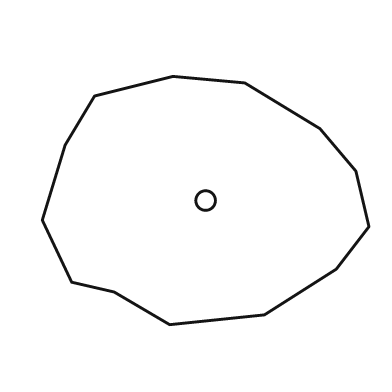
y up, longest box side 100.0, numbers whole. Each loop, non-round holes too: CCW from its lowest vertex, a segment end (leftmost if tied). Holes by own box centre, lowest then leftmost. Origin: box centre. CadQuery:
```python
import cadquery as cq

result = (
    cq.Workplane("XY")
    .moveTo(-11.0, -38.0)
    .lineTo(18.0, -35.0)
    .lineTo(40.0, -21.0)
    .lineTo(50.0, -8.0)
    .lineTo(46.0, 9.0)
    .lineTo(35.0, 22.0)
    .lineTo(12.0, 36.0)
    .lineTo(-10.0, 38.0)
    .lineTo(-34.0, 32.0)
    .lineTo(-43.0, 17.0)
    .lineTo(-50.0, -6.0)
    .lineTo(-41.0, -25.0)
    .lineTo(-28.0, -28.0)
    .close()
    .moveTo(0.0, 0.0)
    .circle(3.0)
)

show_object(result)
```